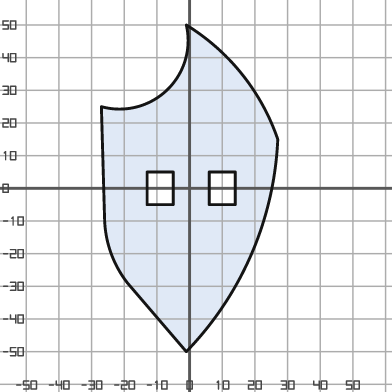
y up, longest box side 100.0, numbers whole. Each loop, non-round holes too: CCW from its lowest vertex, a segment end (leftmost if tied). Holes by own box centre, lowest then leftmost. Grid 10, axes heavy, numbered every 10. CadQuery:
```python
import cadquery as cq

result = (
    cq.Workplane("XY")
    .moveTo(-1.0, -50.0)
    .threePointArc((19.0, -20.0), (27.0, 15.0))
    .threePointArc((16.0, 35.0), (-1.0, 50.0))
    .threePointArc((-7.0, 30.0), (-27.0, 25.0))
    .lineTo(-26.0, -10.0)
    .threePointArc((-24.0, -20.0), (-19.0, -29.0))
    .close()
    .moveTo(-13.0, -5.0)
    .lineTo(-5.0, -5.0)
    .lineTo(-5.0, 5.0)
    .lineTo(-13.0, 5.0)
    .close()
    .moveTo(6.0, -5.0)
    .lineTo(14.0, -5.0)
    .lineTo(14.0, 5.0)
    .lineTo(6.0, 5.0)
    .close()
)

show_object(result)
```